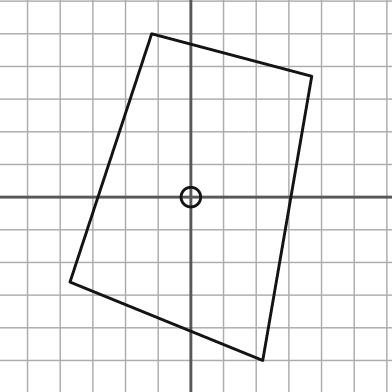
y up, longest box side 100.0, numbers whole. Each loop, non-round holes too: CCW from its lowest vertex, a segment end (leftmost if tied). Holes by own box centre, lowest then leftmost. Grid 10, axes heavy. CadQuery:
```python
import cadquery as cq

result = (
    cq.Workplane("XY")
    .moveTo(22.0, -50.0)
    .lineTo(37.0, 37.0)
    .lineTo(-12.0, 50.0)
    .lineTo(-37.0, -26.0)
    .close()
    .moveTo(0.0, 0.0)
    .circle(3.0)
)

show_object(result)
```